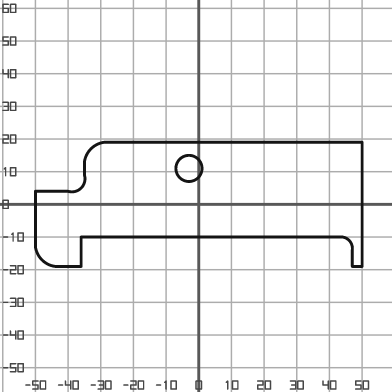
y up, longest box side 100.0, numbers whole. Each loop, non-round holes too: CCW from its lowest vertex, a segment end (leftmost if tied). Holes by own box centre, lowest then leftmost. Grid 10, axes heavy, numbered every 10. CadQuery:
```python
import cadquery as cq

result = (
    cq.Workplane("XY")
    .moveTo(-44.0, -19.0)
    .lineTo(-36.0, -19.0)
    .lineTo(-36.0, -10.0)
    .lineTo(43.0, -10.0)
    .threePointArc((46.0, -11.0), (47.0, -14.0))
    .lineTo(47.0, -19.0)
    .lineTo(50.0, -19.0)
    .lineTo(50.0, 19.0)
    .lineTo(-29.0, 19.0)
    .threePointArc((-33.0, 17.0), (-35.0, 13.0))
    .lineTo(-35.0, 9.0)
    .threePointArc((-36.0, 5.0), (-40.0, 4.0))
    .lineTo(-50.0, 4.0)
    .lineTo(-50.0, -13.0)
    .threePointArc((-48.0, -17.0), (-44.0, -19.0))
    .close()
    .moveTo(-3.0, 11.0)
    .circle(4.0)
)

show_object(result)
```